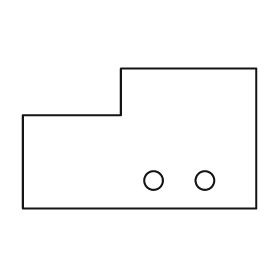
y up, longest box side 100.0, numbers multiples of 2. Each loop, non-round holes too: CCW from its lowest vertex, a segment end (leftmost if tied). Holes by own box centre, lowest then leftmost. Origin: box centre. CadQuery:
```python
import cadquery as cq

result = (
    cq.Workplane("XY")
    .moveTo(-50.0, -30.0)
    .lineTo(50.0, -30.0)
    .lineTo(50.0, 30.0)
    .lineTo(-8.0, 30.0)
    .lineTo(-8.0, 10.0)
    .lineTo(-50.0, 10.0)
    .close()
    .moveTo(6.0, -18.0)
    .circle(4.0)
    .moveTo(28.0, -18.0)
    .circle(4.0)
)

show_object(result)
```